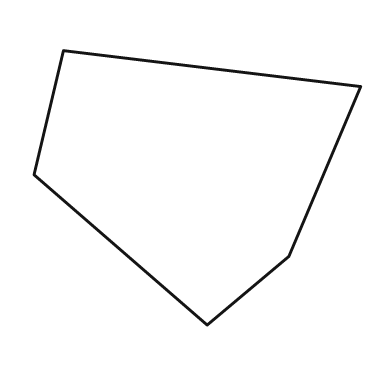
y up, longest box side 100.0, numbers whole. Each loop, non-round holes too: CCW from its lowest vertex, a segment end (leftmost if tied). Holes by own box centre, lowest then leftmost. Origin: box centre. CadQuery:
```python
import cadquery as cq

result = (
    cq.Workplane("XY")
    .moveTo(3.0, -42.0)
    .lineTo(28.0, -21.0)
    .lineTo(50.0, 31.0)
    .lineTo(-41.0, 42.0)
    .lineTo(-50.0, 4.0)
    .close()
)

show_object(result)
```